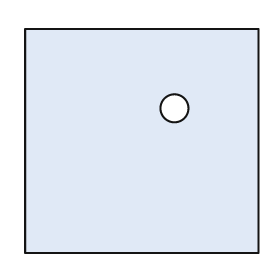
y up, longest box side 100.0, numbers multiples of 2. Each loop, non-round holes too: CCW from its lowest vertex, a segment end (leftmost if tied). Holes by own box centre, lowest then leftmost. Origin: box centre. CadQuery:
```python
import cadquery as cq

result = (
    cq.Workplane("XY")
    .moveTo(-50.0, -48.0)
    .lineTo(50.0, -48.0)
    .lineTo(50.0, 48.0)
    .lineTo(-50.0, 48.0)
    .close()
    .moveTo(14.0, 14.0)
    .circle(6.0)
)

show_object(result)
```